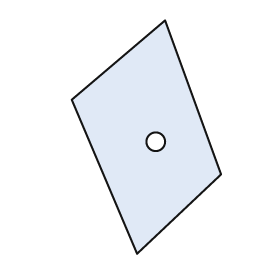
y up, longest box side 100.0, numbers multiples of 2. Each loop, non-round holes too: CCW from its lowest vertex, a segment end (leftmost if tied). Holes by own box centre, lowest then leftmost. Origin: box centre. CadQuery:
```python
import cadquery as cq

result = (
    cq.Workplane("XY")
    .moveTo(-4.0, -50.0)
    .lineTo(32.0, -16.0)
    .lineTo(8.0, 50.0)
    .lineTo(-32.0, 16.0)
    .close()
    .moveTo(4.0, -2.0)
    .circle(4.0)
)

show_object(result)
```